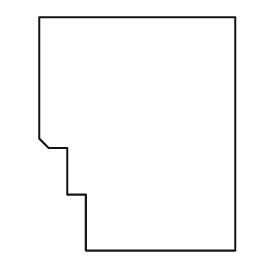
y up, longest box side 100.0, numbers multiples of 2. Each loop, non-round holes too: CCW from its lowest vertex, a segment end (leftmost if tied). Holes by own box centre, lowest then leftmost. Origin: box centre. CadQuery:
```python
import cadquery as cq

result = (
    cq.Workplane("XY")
    .moveTo(-22.0, -50.0)
    .lineTo(42.0, -50.0)
    .lineTo(42.0, 50.0)
    .lineTo(-42.0, 50.0)
    .lineTo(-42.0, -2.0)
    .lineTo(-38.0, -6.0)
    .lineTo(-30.0, -6.0)
    .lineTo(-30.0, -26.0)
    .lineTo(-22.0, -26.0)
    .close()
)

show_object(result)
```